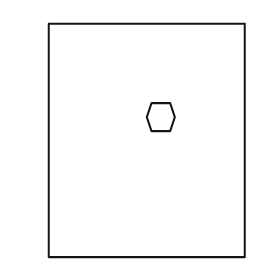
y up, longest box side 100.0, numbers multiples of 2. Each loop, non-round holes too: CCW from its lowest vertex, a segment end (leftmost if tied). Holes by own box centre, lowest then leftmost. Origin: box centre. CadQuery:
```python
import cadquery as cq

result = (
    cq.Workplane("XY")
    .moveTo(-42.0, -50.0)
    .lineTo(42.0, -50.0)
    .lineTo(42.0, 50.0)
    .lineTo(-42.0, 50.0)
    .close()
    .moveTo(2.0, 4.0)
    .lineTo(10.0, 4.0)
    .lineTo(12.0, 10.0)
    .lineTo(10.0, 16.0)
    .lineTo(2.0, 16.0)
    .lineTo(0.0, 10.0)
    .close()
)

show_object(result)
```